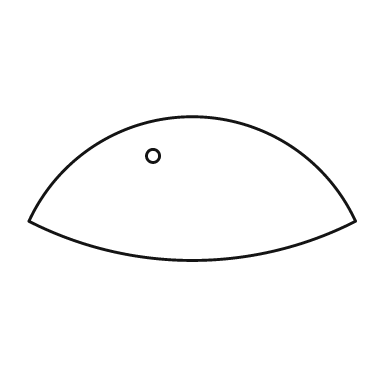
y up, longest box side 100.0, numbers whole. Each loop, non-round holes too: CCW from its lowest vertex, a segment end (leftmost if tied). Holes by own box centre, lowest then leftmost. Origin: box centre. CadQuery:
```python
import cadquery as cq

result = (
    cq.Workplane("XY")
    .moveTo(-50.0, -10.0)
    .threePointArc((0.0, -22.0), (50.0, -10.0))
    .threePointArc((0.0, 22.0), (-50.0, -10.0))
    .close()
    .moveTo(-12.0, 10.0)
    .circle(2.0)
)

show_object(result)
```